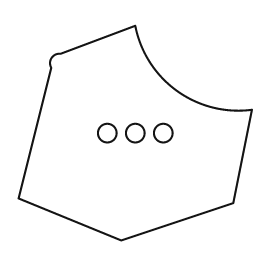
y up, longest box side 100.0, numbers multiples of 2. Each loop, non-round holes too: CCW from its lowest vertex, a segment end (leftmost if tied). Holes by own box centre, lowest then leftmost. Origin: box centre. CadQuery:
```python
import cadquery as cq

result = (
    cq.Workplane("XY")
    .moveTo(-6.0, -46.0)
    .lineTo(42.0, -30.0)
    .lineTo(50.0, 10.0)
    .threePointArc((18.0, 18.0), (0.0, 46.0))
    .lineTo(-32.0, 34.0)
    .threePointArc((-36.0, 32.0), (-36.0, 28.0))
    .lineTo(-50.0, -28.0)
    .close()
    .moveTo(-12.0, 0.0)
    .circle(4.0)
    .moveTo(0.0, 0.0)
    .circle(4.0)
    .moveTo(12.0, 0.0)
    .circle(4.0)
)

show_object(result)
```